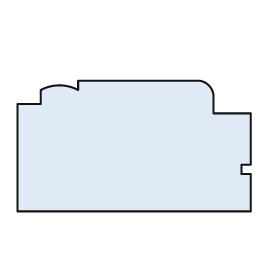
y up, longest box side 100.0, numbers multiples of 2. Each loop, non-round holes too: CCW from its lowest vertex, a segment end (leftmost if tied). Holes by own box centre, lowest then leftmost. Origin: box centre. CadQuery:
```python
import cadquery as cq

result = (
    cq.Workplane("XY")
    .moveTo(-50.0, -28.0)
    .lineTo(50.0, -28.0)
    .lineTo(50.0, -12.0)
    .lineTo(46.0, -12.0)
    .lineTo(46.0, -8.0)
    .lineTo(50.0, -8.0)
    .lineTo(50.0, 14.0)
    .lineTo(34.0, 14.0)
    .lineTo(34.0, 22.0)
    .threePointArc((32.0, 26.0), (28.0, 28.0))
    .lineTo(-24.0, 28.0)
    .lineTo(-24.0, 24.0)
    .threePointArc((-32.0, 26.0), (-40.0, 24.0))
    .lineTo(-40.0, 18.0)
    .lineTo(-50.0, 18.0)
    .close()
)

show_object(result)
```